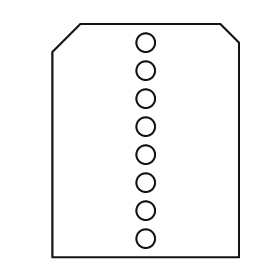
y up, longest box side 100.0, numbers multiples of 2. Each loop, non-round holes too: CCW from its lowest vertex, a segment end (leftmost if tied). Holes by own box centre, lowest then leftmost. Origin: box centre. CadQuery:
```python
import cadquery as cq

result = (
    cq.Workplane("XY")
    .moveTo(-40.0, -50.0)
    .lineTo(40.0, -50.0)
    .lineTo(40.0, 42.0)
    .lineTo(32.0, 50.0)
    .lineTo(-28.0, 50.0)
    .lineTo(-40.0, 38.0)
    .close()
    .moveTo(0.0, -42.0)
    .circle(4.0)
    .moveTo(0.0, -30.0)
    .circle(4.0)
    .moveTo(0.0, -18.0)
    .circle(4.0)
    .moveTo(0.0, -6.0)
    .circle(4.0)
    .moveTo(0.0, 6.0)
    .circle(4.0)
    .moveTo(0.0, 18.0)
    .circle(4.0)
    .moveTo(0.0, 30.0)
    .circle(4.0)
    .moveTo(0.0, 42.0)
    .circle(4.0)
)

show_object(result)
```